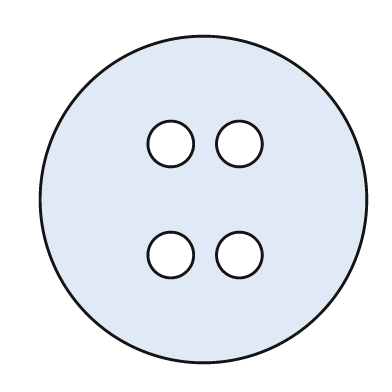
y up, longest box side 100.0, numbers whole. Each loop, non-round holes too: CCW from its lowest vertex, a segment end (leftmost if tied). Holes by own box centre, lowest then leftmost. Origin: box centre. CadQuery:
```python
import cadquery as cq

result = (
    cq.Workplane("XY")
    .moveTo(0.0, 0.0)
    .circle(50.0)
    .moveTo(-10.0, -17.0)
    .circle(7.0)
    .moveTo(11.0, -17.0)
    .circle(7.0)
    .moveTo(-10.0, 17.0)
    .circle(7.0)
    .moveTo(11.0, 17.0)
    .circle(7.0)
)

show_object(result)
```